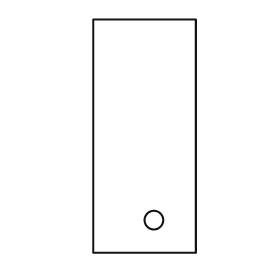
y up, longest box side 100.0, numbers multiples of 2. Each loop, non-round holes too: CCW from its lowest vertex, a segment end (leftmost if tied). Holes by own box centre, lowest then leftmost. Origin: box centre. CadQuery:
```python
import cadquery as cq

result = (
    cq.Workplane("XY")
    .moveTo(-22.0, -50.0)
    .lineTo(22.0, -50.0)
    .lineTo(22.0, 50.0)
    .lineTo(-22.0, 50.0)
    .close()
    .moveTo(4.0, -36.0)
    .circle(4.0)
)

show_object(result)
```